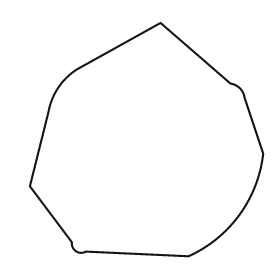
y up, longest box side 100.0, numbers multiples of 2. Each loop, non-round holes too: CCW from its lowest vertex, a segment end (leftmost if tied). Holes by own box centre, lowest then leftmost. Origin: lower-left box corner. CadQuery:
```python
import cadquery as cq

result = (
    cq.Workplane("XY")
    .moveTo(68.0, 0.0)
    .threePointArc((90.0, 18.0), (100.0, 44.0))
    .lineTo(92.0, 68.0)
    .threePointArc((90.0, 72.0), (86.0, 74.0))
    .lineTo(56.0, 100.0)
    .lineTo(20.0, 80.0)
    .threePointArc((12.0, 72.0), (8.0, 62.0))
    .lineTo(0.0, 30.0)
    .lineTo(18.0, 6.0)
    .threePointArc((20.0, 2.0), (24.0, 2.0))
    .close()
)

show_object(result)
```